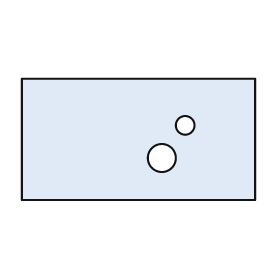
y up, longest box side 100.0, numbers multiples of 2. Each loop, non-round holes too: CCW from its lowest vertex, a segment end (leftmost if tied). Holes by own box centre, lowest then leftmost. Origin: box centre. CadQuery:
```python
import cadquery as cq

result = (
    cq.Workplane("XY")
    .moveTo(-50.0, -26.0)
    .lineTo(50.0, -26.0)
    .lineTo(50.0, 26.0)
    .lineTo(-50.0, 26.0)
    .close()
    .moveTo(10.0, -8.0)
    .circle(6.0)
    .moveTo(20.0, 6.0)
    .circle(4.0)
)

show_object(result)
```